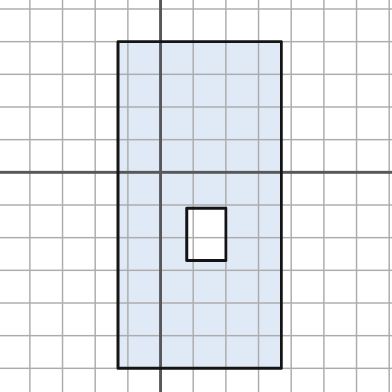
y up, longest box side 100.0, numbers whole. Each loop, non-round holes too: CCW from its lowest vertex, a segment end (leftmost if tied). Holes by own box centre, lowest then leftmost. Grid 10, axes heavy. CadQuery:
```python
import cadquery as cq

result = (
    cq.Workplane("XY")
    .moveTo(-13.0, -60.0)
    .lineTo(37.0, -60.0)
    .lineTo(37.0, 40.0)
    .lineTo(-13.0, 40.0)
    .close()
    .moveTo(8.0, -27.0)
    .lineTo(20.0, -27.0)
    .lineTo(20.0, -11.0)
    .lineTo(8.0, -11.0)
    .close()
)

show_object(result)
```